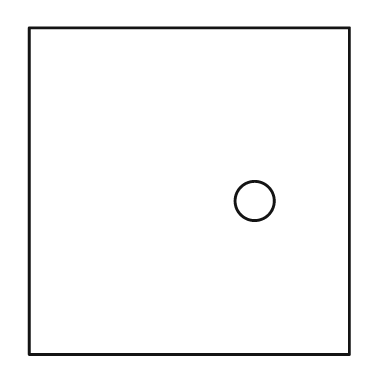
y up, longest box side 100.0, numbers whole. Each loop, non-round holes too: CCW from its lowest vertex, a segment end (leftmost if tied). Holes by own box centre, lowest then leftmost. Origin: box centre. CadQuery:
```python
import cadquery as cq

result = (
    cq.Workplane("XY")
    .moveTo(-49.0, -50.0)
    .lineTo(49.0, -50.0)
    .lineTo(49.0, 50.0)
    .lineTo(-49.0, 50.0)
    .close()
    .moveTo(20.0, -3.0)
    .circle(6.0)
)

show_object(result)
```